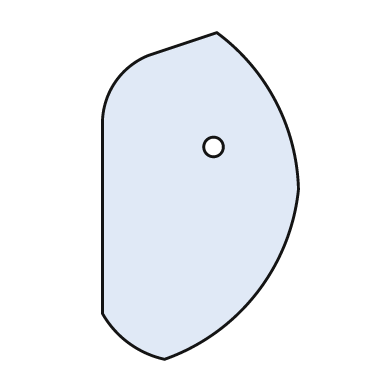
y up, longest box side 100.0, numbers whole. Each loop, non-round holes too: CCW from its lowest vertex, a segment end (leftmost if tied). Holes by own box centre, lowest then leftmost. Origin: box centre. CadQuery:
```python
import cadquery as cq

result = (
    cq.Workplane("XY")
    .moveTo(-11.0, -50.0)
    .threePointArc((17.0, -30.0), (30.0, 2.0))
    .threePointArc((23.0, 29.0), (5.0, 50.0))
    .lineTo(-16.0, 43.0)
    .threePointArc((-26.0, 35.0), (-30.0, 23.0))
    .lineTo(-30.0, -36.0)
    .threePointArc((-22.0, -45.0), (-11.0, -50.0))
    .close()
    .moveTo(4.0, 15.0)
    .circle(3.0)
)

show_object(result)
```